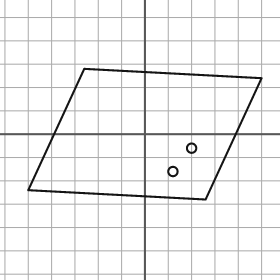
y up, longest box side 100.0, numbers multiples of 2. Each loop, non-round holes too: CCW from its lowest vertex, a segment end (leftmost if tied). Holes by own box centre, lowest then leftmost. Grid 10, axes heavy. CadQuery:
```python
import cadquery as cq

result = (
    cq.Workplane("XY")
    .moveTo(26.0, -28.0)
    .lineTo(50.0, 24.0)
    .lineTo(-26.0, 28.0)
    .lineTo(-50.0, -24.0)
    .close()
    .moveTo(12.0, -16.0)
    .circle(2.0)
    .moveTo(20.0, -6.0)
    .circle(2.0)
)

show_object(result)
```